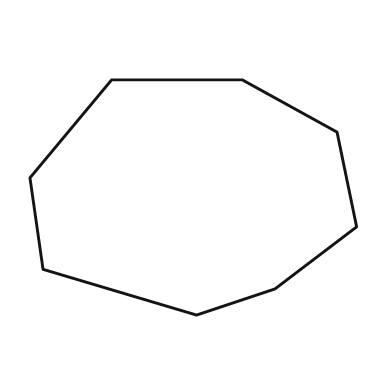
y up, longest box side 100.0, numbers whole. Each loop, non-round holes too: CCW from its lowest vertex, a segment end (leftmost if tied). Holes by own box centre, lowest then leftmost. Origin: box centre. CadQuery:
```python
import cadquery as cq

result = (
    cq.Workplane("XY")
    .moveTo(1.0, -36.0)
    .lineTo(25.0, -28.0)
    .lineTo(50.0, -9.0)
    .lineTo(44.0, 20.0)
    .lineTo(15.0, 36.0)
    .lineTo(-25.0, 36.0)
    .lineTo(-50.0, 6.0)
    .lineTo(-46.0, -22.0)
    .close()
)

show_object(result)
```